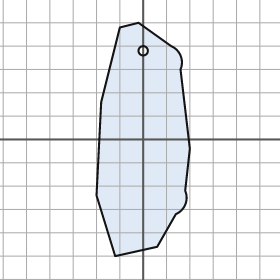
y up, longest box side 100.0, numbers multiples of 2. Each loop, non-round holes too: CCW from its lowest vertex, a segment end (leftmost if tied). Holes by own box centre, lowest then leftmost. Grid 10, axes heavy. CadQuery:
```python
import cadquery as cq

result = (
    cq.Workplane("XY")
    .moveTo(-12.0, -50.0)
    .lineTo(6.0, -46.0)
    .lineTo(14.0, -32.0)
    .threePointArc((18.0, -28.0), (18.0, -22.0))
    .lineTo(20.0, -4.0)
    .lineTo(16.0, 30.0)
    .threePointArc((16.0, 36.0), (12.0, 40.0))
    .lineTo(-2.0, 50.0)
    .lineTo(-10.0, 48.0)
    .lineTo(-18.0, 16.0)
    .lineTo(-20.0, -24.0)
    .close()
    .moveTo(0.0, 38.0)
    .circle(2.0)
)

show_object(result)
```